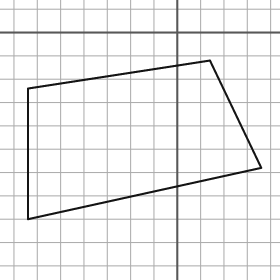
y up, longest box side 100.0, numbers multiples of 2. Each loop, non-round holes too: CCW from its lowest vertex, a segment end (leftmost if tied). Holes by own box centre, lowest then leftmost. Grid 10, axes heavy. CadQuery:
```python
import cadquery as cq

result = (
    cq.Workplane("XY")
    .moveTo(-64.0, -80.0)
    .lineTo(36.0, -58.0)
    .lineTo(14.0, -12.0)
    .lineTo(-64.0, -24.0)
    .close()
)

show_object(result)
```